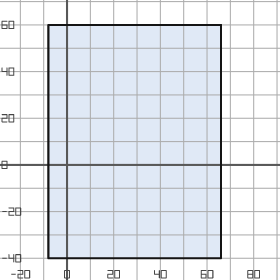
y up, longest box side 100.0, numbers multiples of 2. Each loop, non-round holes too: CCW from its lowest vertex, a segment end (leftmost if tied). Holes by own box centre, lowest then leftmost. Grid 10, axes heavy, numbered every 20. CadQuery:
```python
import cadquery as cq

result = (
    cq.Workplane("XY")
    .moveTo(-8.0, -40.0)
    .lineTo(66.0, -40.0)
    .lineTo(66.0, 60.0)
    .lineTo(-8.0, 60.0)
    .close()
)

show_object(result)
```